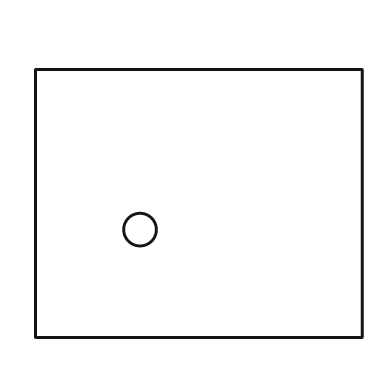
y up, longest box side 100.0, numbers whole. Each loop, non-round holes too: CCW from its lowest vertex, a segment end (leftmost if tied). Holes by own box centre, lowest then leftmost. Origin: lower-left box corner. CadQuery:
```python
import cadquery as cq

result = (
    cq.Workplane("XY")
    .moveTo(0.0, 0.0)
    .lineTo(100.0, 0.0)
    .lineTo(100.0, 82.0)
    .lineTo(0.0, 82.0)
    .close()
    .moveTo(32.0, 33.0)
    .circle(5.0)
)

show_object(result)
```